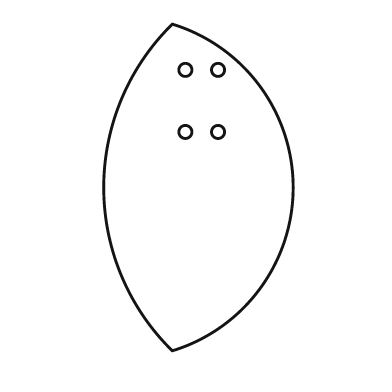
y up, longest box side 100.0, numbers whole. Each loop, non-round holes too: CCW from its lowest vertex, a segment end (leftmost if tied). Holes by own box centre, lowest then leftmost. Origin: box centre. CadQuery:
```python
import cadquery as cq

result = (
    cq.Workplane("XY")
    .moveTo(-8.0, -50.0)
    .threePointArc((29.0, 0.0), (-8.0, 50.0))
    .threePointArc((-29.0, 0.0), (-8.0, -50.0))
    .close()
    .moveTo(-4.0, 17.0)
    .circle(2.0)
    .moveTo(6.0, 17.0)
    .circle(2.0)
    .moveTo(-4.0, 36.0)
    .circle(2.0)
    .moveTo(6.0, 36.0)
    .circle(2.0)
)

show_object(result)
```